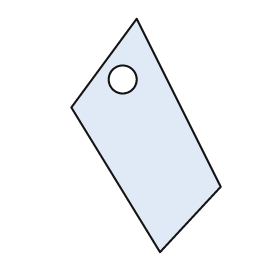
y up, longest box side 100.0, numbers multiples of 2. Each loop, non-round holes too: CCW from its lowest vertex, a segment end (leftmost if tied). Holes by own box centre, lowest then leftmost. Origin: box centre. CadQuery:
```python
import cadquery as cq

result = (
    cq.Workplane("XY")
    .moveTo(6.0, -50.0)
    .lineTo(32.0, -22.0)
    .lineTo(-4.0, 50.0)
    .lineTo(-32.0, 12.0)
    .close()
    .moveTo(-10.0, 24.0)
    .circle(6.0)
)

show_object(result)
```